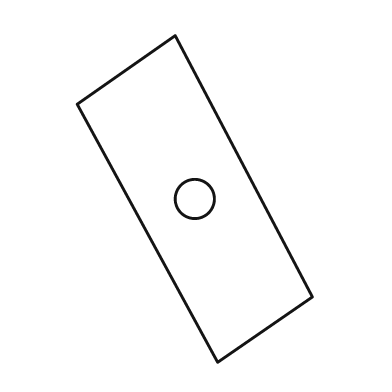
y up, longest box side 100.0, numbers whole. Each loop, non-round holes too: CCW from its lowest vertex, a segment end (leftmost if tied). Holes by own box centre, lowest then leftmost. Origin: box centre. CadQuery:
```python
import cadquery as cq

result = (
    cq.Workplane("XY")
    .moveTo(7.0, -50.0)
    .lineTo(36.0, -30.0)
    .lineTo(-6.0, 50.0)
    .lineTo(-36.0, 29.0)
    .close()
    .moveTo(0.0, 0.0)
    .circle(6.0)
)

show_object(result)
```